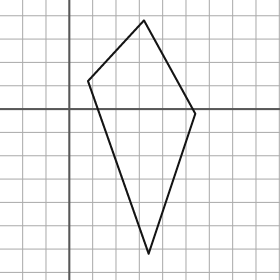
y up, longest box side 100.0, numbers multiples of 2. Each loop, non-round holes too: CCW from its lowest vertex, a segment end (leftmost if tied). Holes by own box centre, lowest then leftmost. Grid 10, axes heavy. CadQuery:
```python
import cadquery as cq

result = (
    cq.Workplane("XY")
    .moveTo(34.0, -62.0)
    .lineTo(54.0, -2.0)
    .lineTo(32.0, 38.0)
    .lineTo(8.0, 12.0)
    .close()
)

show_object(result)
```